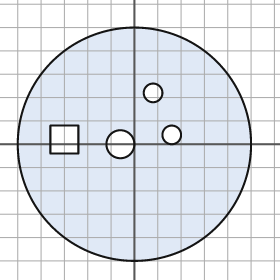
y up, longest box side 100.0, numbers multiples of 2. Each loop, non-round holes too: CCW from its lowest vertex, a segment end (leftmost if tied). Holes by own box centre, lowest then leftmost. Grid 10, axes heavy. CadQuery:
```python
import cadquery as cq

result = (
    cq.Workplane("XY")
    .moveTo(0.0, 0.0)
    .circle(50.0)
    .moveTo(-6.0, 0.0)
    .circle(6.0)
    .moveTo(-36.0, -4.0)
    .lineTo(-24.0, -4.0)
    .lineTo(-24.0, 8.0)
    .lineTo(-36.0, 8.0)
    .close()
    .moveTo(16.0, 4.0)
    .circle(4.0)
    .moveTo(8.0, 22.0)
    .circle(4.0)
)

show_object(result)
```